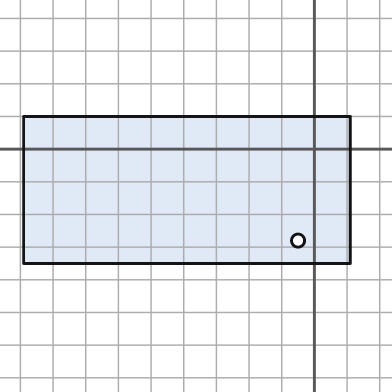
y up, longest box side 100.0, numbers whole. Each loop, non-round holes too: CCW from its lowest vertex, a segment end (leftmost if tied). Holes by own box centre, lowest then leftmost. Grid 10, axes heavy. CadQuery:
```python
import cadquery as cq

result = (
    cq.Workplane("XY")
    .moveTo(-89.0, -35.0)
    .lineTo(11.0, -35.0)
    .lineTo(11.0, 10.0)
    .lineTo(-89.0, 10.0)
    .close()
    .moveTo(-5.0, -28.0)
    .circle(2.0)
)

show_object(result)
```